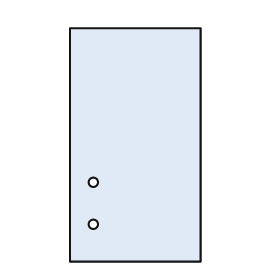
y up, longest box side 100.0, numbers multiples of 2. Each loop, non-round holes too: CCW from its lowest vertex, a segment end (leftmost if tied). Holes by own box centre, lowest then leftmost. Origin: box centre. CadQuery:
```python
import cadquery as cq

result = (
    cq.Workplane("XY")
    .moveTo(-28.0, -50.0)
    .lineTo(28.0, -50.0)
    .lineTo(28.0, 50.0)
    .lineTo(-28.0, 50.0)
    .close()
    .moveTo(-18.0, -34.0)
    .circle(2.0)
    .moveTo(-18.0, -16.0)
    .circle(2.0)
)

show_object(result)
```